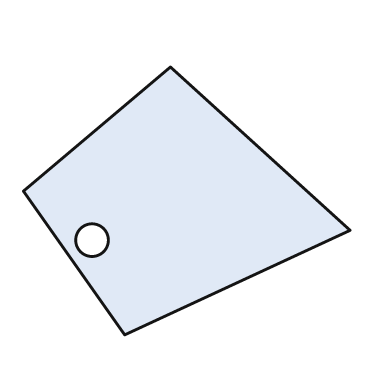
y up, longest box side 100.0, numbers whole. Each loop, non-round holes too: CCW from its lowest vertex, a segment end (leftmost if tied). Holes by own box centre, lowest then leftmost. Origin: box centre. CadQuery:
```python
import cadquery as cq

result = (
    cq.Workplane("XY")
    .moveTo(-19.0, -41.0)
    .lineTo(50.0, -9.0)
    .lineTo(-5.0, 41.0)
    .lineTo(-50.0, 3.0)
    .close()
    .moveTo(-29.0, -12.0)
    .circle(5.0)
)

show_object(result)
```